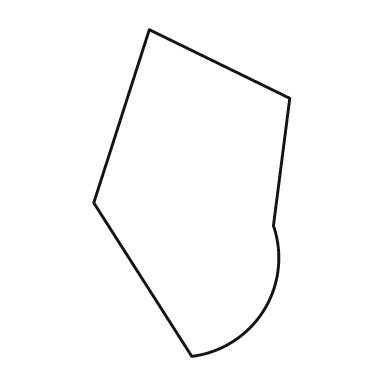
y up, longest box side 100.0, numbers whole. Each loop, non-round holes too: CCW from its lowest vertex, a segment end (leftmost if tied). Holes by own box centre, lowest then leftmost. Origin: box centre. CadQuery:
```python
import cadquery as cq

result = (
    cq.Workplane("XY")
    .moveTo(0.0, -50.0)
    .threePointArc((22.0, -36.0), (25.0, -10.0))
    .lineTo(30.0, 29.0)
    .lineTo(-13.0, 50.0)
    .lineTo(-30.0, -3.0)
    .close()
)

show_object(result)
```